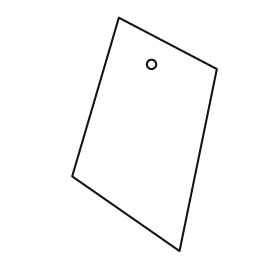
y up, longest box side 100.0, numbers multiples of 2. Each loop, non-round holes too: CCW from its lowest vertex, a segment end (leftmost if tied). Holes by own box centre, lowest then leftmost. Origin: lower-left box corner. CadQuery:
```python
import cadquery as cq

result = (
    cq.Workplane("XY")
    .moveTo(46.0, 0.0)
    .lineTo(62.0, 78.0)
    .lineTo(20.0, 100.0)
    .lineTo(0.0, 32.0)
    .close()
    .moveTo(34.0, 80.0)
    .circle(2.0)
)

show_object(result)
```